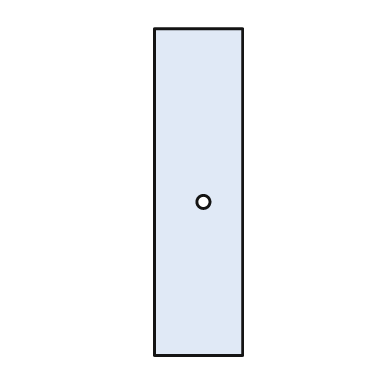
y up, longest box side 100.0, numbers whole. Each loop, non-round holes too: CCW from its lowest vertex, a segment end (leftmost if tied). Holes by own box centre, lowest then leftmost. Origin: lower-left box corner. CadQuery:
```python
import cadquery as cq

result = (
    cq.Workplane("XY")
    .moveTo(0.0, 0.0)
    .lineTo(27.0, 0.0)
    .lineTo(27.0, 100.0)
    .lineTo(0.0, 100.0)
    .close()
    .moveTo(15.0, 47.0)
    .circle(2.0)
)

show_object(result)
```